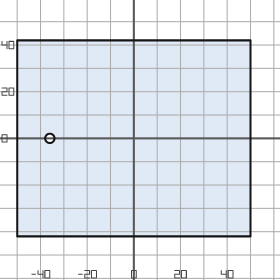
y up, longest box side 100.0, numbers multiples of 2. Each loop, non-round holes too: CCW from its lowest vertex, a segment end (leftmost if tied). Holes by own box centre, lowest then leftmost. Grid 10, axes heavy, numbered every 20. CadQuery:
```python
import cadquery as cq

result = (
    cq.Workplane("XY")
    .moveTo(-50.0, -42.0)
    .lineTo(50.0, -42.0)
    .lineTo(50.0, 42.0)
    .lineTo(-50.0, 42.0)
    .close()
    .moveTo(-36.0, 0.0)
    .circle(2.0)
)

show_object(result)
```